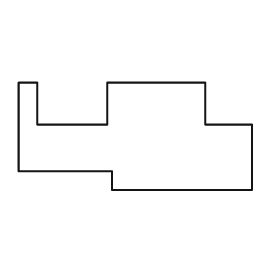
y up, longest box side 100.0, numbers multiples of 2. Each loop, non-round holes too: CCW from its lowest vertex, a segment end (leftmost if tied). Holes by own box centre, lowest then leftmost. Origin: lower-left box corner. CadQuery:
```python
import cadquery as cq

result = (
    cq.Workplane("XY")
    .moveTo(40.0, 0.0)
    .lineTo(100.0, 0.0)
    .lineTo(100.0, 28.0)
    .lineTo(80.0, 28.0)
    .lineTo(80.0, 46.0)
    .lineTo(38.0, 46.0)
    .lineTo(38.0, 28.0)
    .lineTo(8.0, 28.0)
    .lineTo(8.0, 46.0)
    .lineTo(0.0, 46.0)
    .lineTo(0.0, 8.0)
    .lineTo(40.0, 8.0)
    .close()
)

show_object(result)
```